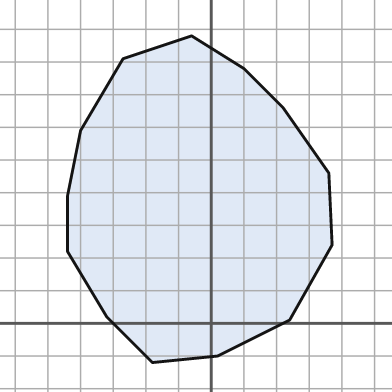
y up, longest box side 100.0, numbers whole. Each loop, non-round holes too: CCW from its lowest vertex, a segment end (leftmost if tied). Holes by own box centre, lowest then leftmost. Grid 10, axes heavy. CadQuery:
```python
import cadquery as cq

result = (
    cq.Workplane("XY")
    .moveTo(-18.0, -12.0)
    .lineTo(2.0, -10.0)
    .lineTo(24.0, 1.0)
    .lineTo(37.0, 24.0)
    .lineTo(36.0, 46.0)
    .lineTo(22.0, 66.0)
    .lineTo(10.0, 78.0)
    .lineTo(-6.0, 88.0)
    .lineTo(-27.0, 81.0)
    .lineTo(-40.0, 59.0)
    .lineTo(-44.0, 39.0)
    .lineTo(-44.0, 22.0)
    .lineTo(-32.0, 2.0)
    .close()
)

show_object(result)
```